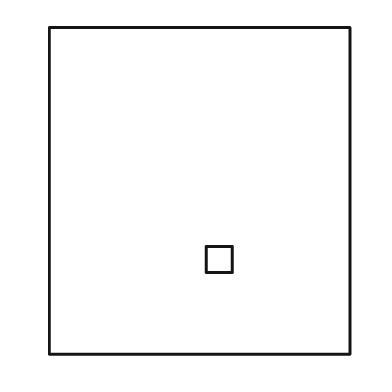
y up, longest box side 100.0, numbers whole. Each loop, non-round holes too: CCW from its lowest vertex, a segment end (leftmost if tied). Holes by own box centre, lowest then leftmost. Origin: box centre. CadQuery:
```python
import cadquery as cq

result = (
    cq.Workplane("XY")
    .moveTo(-46.0, -50.0)
    .lineTo(46.0, -50.0)
    .lineTo(46.0, 50.0)
    .lineTo(-46.0, 50.0)
    .close()
    .moveTo(2.0, -25.0)
    .lineTo(10.0, -25.0)
    .lineTo(10.0, -17.0)
    .lineTo(2.0, -17.0)
    .close()
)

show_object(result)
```